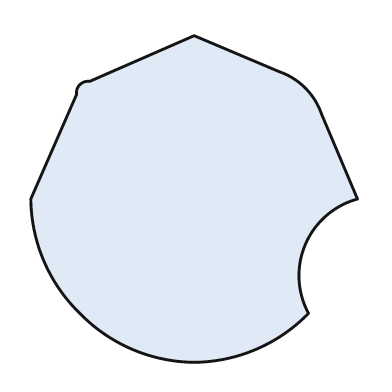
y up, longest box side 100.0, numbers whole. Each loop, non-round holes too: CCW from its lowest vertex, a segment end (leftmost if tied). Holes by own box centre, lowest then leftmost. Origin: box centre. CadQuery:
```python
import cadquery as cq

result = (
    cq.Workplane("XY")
    .moveTo(0.0, -50.0)
    .threePointArc((19.0, -46.0), (35.0, -35.0))
    .threePointArc((34.0, -14.0), (50.0, 0.0))
    .lineTo(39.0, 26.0)
    .threePointArc((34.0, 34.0), (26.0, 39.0))
    .lineTo(0.0, 50.0)
    .lineTo(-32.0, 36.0)
    .threePointArc((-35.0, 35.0), (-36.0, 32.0))
    .lineTo(-50.0, 0.0)
    .threePointArc((-46.0, -19.0), (-35.0, -35.0))
    .threePointArc((-19.0, -46.0), (0.0, -50.0))
    .close()
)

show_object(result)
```